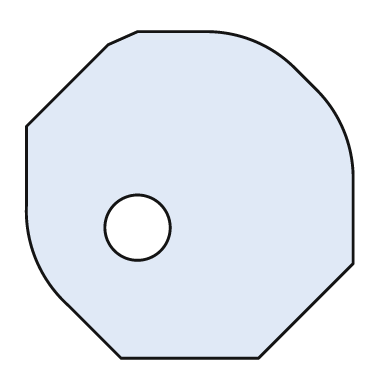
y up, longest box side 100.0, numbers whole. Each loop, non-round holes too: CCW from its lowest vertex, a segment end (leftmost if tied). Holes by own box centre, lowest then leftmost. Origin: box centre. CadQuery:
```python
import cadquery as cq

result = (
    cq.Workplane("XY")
    .moveTo(-21.0, -50.0)
    .lineTo(21.0, -50.0)
    .lineTo(50.0, -21.0)
    .lineTo(50.0, 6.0)
    .threePointArc((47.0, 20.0), (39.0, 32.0))
    .lineTo(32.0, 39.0)
    .threePointArc((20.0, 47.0), (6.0, 50.0))
    .lineTo(-16.0, 50.0)
    .lineTo(-25.0, 46.0)
    .lineTo(-50.0, 21.0)
    .lineTo(-50.0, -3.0)
    .threePointArc((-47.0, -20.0), (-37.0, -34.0))
    .close()
    .moveTo(-16.0, -10.0)
    .circle(10.0)
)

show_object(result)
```